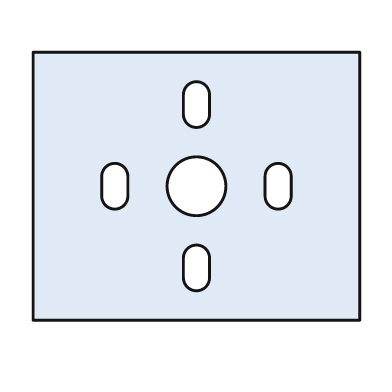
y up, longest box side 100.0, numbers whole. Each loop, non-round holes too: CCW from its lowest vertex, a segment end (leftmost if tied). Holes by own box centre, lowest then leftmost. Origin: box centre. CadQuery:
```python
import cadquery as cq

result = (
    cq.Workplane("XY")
    .moveTo(-50.0, -41.0)
    .lineTo(50.0, -41.0)
    .lineTo(50.0, 41.0)
    .lineTo(-50.0, 41.0)
    .close()
    .moveTo(-4.0, -28.0)
    .threePointArc((0.0, -32.0), (4.0, -28.0))
    .lineTo(4.0, -22.0)
    .threePointArc((0.0, -18.0), (-4.0, -22.0))
    .close()
    .moveTo(-29.0, -3.0)
    .threePointArc((-25.0, -7.0), (-21.0, -3.0))
    .lineTo(-21.0, 3.0)
    .threePointArc((-25.0, 7.0), (-29.0, 3.0))
    .close()
    .moveTo(0.0, 0.0)
    .circle(9.0)
    .moveTo(21.0, -3.0)
    .threePointArc((25.0, -7.0), (29.0, -3.0))
    .lineTo(29.0, 3.0)
    .threePointArc((25.0, 7.0), (21.0, 3.0))
    .close()
    .moveTo(-4.0, 22.0)
    .threePointArc((0.0, 18.0), (4.0, 22.0))
    .lineTo(4.0, 28.0)
    .threePointArc((0.0, 32.0), (-4.0, 28.0))
    .close()
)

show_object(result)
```